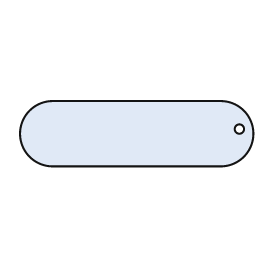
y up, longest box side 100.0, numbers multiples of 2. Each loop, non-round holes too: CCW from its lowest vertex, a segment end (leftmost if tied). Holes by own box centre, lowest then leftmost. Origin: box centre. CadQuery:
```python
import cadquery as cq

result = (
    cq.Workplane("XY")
    .moveTo(-36.0, -14.0)
    .lineTo(36.0, -14.0)
    .threePointArc((50.0, 0.0), (36.0, 14.0))
    .lineTo(-36.0, 14.0)
    .threePointArc((-50.0, 0.0), (-36.0, -14.0))
    .close()
    .moveTo(44.0, 2.0)
    .circle(2.0)
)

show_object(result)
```